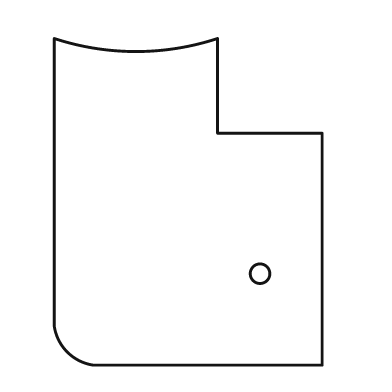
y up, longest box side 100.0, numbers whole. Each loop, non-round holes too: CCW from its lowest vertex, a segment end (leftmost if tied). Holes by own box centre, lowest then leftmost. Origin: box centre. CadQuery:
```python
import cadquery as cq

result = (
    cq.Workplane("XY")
    .moveTo(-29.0, -50.0)
    .lineTo(41.0, -50.0)
    .lineTo(41.0, 21.0)
    .lineTo(9.0, 21.0)
    .lineTo(9.0, 50.0)
    .threePointArc((-16.0, 46.0), (-41.0, 50.0))
    .lineTo(-41.0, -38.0)
    .threePointArc((-37.0, -46.0), (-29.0, -50.0))
    .close()
    .moveTo(22.0, -22.0)
    .circle(3.0)
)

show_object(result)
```